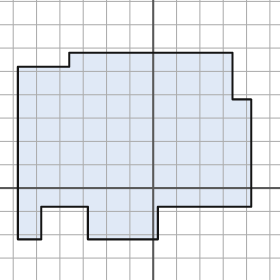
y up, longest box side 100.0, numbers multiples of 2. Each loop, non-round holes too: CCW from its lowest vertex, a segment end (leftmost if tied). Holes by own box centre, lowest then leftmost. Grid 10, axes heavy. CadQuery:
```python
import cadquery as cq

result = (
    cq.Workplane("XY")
    .moveTo(-58.0, -22.0)
    .lineTo(-48.0, -22.0)
    .lineTo(-48.0, -8.0)
    .lineTo(-28.0, -8.0)
    .lineTo(-28.0, -22.0)
    .lineTo(2.0, -22.0)
    .lineTo(2.0, -8.0)
    .lineTo(42.0, -8.0)
    .lineTo(42.0, 38.0)
    .lineTo(34.0, 38.0)
    .lineTo(34.0, 58.0)
    .lineTo(-36.0, 58.0)
    .lineTo(-36.0, 52.0)
    .lineTo(-58.0, 52.0)
    .close()
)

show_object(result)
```